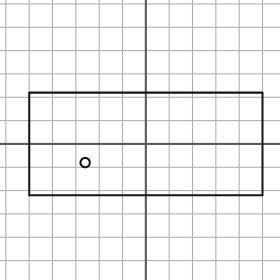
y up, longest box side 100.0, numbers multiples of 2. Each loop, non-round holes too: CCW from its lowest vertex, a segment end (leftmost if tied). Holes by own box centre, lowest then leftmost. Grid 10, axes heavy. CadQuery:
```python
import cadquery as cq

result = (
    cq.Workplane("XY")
    .moveTo(-50.0, -22.0)
    .lineTo(50.0, -22.0)
    .lineTo(50.0, 22.0)
    .lineTo(-50.0, 22.0)
    .close()
    .moveTo(-26.0, -8.0)
    .circle(2.0)
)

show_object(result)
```